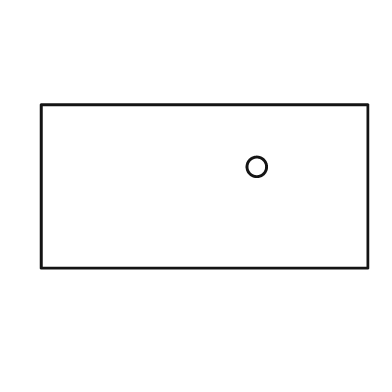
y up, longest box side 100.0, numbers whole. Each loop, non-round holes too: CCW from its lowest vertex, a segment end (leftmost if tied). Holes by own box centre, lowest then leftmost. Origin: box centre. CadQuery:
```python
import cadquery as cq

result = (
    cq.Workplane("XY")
    .moveTo(-50.0, -25.0)
    .lineTo(50.0, -25.0)
    .lineTo(50.0, 25.0)
    .lineTo(-50.0, 25.0)
    .close()
    .moveTo(16.0, 6.0)
    .circle(3.0)
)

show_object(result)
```